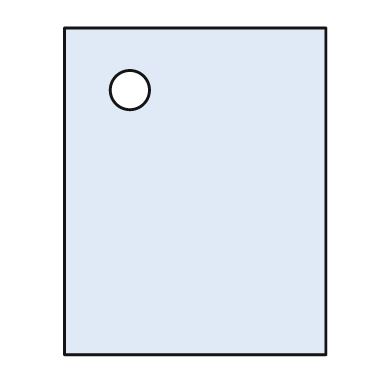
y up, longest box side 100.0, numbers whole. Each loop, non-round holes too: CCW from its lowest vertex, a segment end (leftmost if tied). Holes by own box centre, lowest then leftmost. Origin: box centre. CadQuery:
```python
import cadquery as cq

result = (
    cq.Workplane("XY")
    .moveTo(-40.0, -50.0)
    .lineTo(40.0, -50.0)
    .lineTo(40.0, 50.0)
    .lineTo(-40.0, 50.0)
    .close()
    .moveTo(-20.0, 31.0)
    .circle(6.0)
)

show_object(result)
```